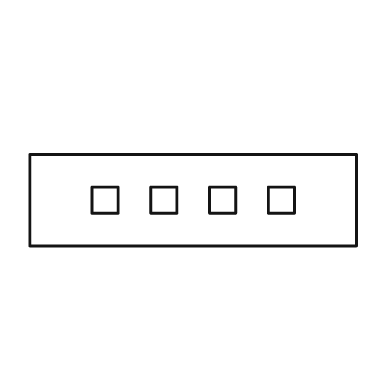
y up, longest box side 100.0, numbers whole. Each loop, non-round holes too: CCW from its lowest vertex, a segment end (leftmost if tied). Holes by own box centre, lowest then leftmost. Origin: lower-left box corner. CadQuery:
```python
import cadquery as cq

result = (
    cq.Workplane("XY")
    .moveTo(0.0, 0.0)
    .lineTo(100.0, 0.0)
    .lineTo(100.0, 28.0)
    .lineTo(0.0, 28.0)
    .close()
    .moveTo(19.0, 10.0)
    .lineTo(27.0, 10.0)
    .lineTo(27.0, 18.0)
    .lineTo(19.0, 18.0)
    .close()
    .moveTo(37.0, 10.0)
    .lineTo(45.0, 10.0)
    .lineTo(45.0, 18.0)
    .lineTo(37.0, 18.0)
    .close()
    .moveTo(55.0, 10.0)
    .lineTo(63.0, 10.0)
    .lineTo(63.0, 18.0)
    .lineTo(55.0, 18.0)
    .close()
    .moveTo(73.0, 10.0)
    .lineTo(81.0, 10.0)
    .lineTo(81.0, 18.0)
    .lineTo(73.0, 18.0)
    .close()
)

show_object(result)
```